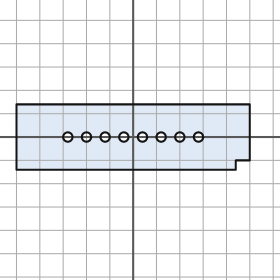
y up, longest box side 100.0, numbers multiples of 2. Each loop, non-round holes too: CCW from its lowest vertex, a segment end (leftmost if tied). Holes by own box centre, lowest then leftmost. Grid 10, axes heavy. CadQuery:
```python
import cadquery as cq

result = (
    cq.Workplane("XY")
    .moveTo(-50.0, -14.0)
    .lineTo(44.0, -14.0)
    .lineTo(44.0, -10.0)
    .lineTo(50.0, -10.0)
    .lineTo(50.0, 14.0)
    .lineTo(-50.0, 14.0)
    .close()
    .moveTo(-28.0, 0.0)
    .circle(2.0)
    .moveTo(-20.0, 0.0)
    .circle(2.0)
    .moveTo(-12.0, 0.0)
    .circle(2.0)
    .moveTo(-4.0, 0.0)
    .circle(2.0)
    .moveTo(4.0, 0.0)
    .circle(2.0)
    .moveTo(12.0, 0.0)
    .circle(2.0)
    .moveTo(20.0, 0.0)
    .circle(2.0)
    .moveTo(28.0, 0.0)
    .circle(2.0)
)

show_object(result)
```